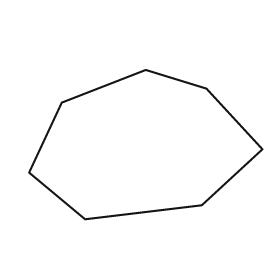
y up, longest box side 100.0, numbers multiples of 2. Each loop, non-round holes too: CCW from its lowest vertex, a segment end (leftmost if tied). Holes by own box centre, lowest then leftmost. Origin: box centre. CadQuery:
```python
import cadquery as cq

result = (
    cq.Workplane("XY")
    .moveTo(-26.0, -32.0)
    .lineTo(24.0, -26.0)
    .lineTo(50.0, -2.0)
    .lineTo(26.0, 24.0)
    .lineTo(0.0, 32.0)
    .lineTo(-36.0, 18.0)
    .lineTo(-50.0, -12.0)
    .close()
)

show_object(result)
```